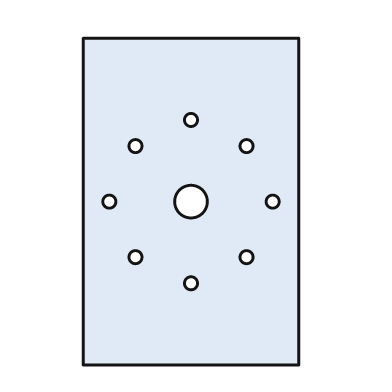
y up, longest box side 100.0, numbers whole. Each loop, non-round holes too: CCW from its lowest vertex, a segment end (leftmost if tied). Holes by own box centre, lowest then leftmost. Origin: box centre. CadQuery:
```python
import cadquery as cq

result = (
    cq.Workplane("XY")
    .moveTo(-33.0, -50.0)
    .lineTo(33.0, -50.0)
    .lineTo(33.0, 50.0)
    .lineTo(-33.0, 50.0)
    .close()
    .moveTo(0.0, -25.0)
    .circle(2.0)
    .moveTo(-17.0, -17.0)
    .circle(2.0)
    .moveTo(17.0, -17.0)
    .circle(2.0)
    .moveTo(-25.0, 0.0)
    .circle(2.0)
    .moveTo(0.0, 0.0)
    .circle(5.0)
    .moveTo(25.0, 0.0)
    .circle(2.0)
    .moveTo(-17.0, 17.0)
    .circle(2.0)
    .moveTo(17.0, 17.0)
    .circle(2.0)
    .moveTo(0.0, 25.0)
    .circle(2.0)
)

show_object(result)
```